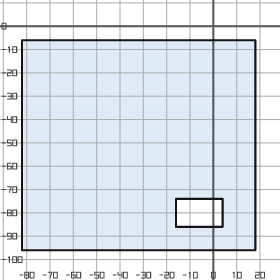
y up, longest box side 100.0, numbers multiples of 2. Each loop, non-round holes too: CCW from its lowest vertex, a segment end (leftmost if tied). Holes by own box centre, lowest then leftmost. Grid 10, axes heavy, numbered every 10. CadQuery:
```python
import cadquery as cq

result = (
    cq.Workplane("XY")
    .moveTo(-82.0, -96.0)
    .lineTo(18.0, -96.0)
    .lineTo(18.0, -6.0)
    .lineTo(-82.0, -6.0)
    .close()
    .moveTo(-16.0, -86.0)
    .lineTo(4.0, -86.0)
    .lineTo(4.0, -74.0)
    .lineTo(-16.0, -74.0)
    .close()
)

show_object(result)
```